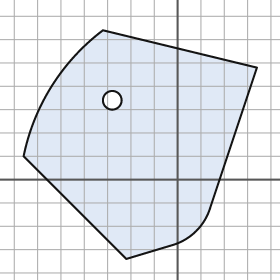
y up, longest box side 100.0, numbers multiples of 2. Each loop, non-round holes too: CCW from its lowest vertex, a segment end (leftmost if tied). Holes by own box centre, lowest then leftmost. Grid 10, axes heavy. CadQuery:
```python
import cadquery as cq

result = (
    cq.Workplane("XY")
    .moveTo(-22.0, -34.0)
    .lineTo(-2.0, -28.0)
    .threePointArc((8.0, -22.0), (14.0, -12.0))
    .lineTo(34.0, 48.0)
    .lineTo(-32.0, 64.0)
    .threePointArc((-54.0, 40.0), (-66.0, 10.0))
    .close()
    .moveTo(-28.0, 34.0)
    .circle(4.0)
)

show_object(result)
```